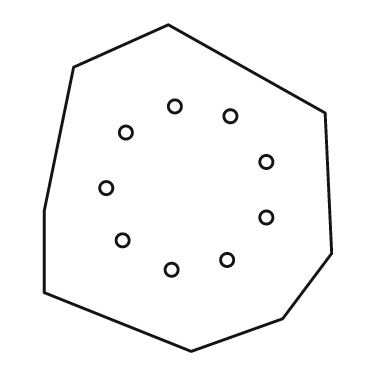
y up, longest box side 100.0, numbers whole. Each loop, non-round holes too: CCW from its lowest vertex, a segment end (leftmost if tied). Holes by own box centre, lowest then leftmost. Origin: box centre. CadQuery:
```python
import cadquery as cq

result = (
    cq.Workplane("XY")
    .moveTo(1.0, -50.0)
    .lineTo(29.0, -40.0)
    .lineTo(44.0, -20.0)
    .lineTo(42.0, 23.0)
    .lineTo(-6.0, 50.0)
    .lineTo(-35.0, 37.0)
    .lineTo(-44.0, -7.0)
    .lineTo(-44.0, -32.0)
    .close()
    .moveTo(-5.0, -25.0)
    .circle(2.0)
    .moveTo(12.0, -22.0)
    .circle(2.0)
    .moveTo(-20.0, -16.0)
    .circle(2.0)
    .moveTo(24.0, -9.0)
    .circle(2.0)
    .moveTo(-25.0, 0.0)
    .circle(2.0)
    .moveTo(24.0, 8.0)
    .circle(2.0)
    .moveTo(-19.0, 17.0)
    .circle(2.0)
    .moveTo(13.0, 22.0)
    .circle(2.0)
    .moveTo(-4.0, 25.0)
    .circle(2.0)
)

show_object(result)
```